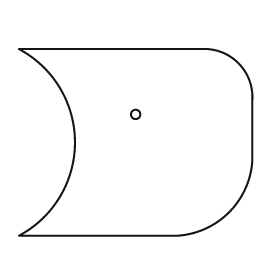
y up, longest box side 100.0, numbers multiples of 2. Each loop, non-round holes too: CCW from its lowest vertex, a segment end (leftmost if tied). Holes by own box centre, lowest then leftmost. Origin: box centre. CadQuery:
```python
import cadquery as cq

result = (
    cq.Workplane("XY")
    .moveTo(-50.0, -40.0)
    .lineTo(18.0, -40.0)
    .threePointArc((40.0, -30.0), (50.0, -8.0))
    .lineTo(50.0, 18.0)
    .threePointArc((44.0, 34.0), (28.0, 40.0))
    .lineTo(-50.0, 40.0)
    .threePointArc((-26.0, 0.0), (-50.0, -40.0))
    .close()
    .moveTo(0.0, 12.0)
    .circle(2.0)
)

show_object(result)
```